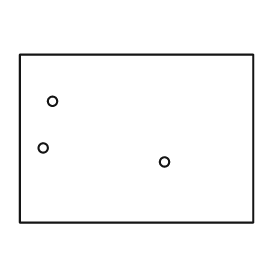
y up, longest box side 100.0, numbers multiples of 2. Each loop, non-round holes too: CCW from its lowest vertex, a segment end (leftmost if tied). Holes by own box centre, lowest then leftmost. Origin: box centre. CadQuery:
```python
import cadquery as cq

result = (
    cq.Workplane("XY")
    .moveTo(-50.0, -36.0)
    .lineTo(50.0, -36.0)
    .lineTo(50.0, 36.0)
    .lineTo(-50.0, 36.0)
    .close()
    .moveTo(12.0, -10.0)
    .circle(2.0)
    .moveTo(-40.0, -4.0)
    .circle(2.0)
    .moveTo(-36.0, 16.0)
    .circle(2.0)
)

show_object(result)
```